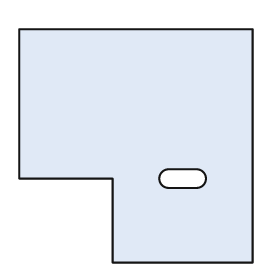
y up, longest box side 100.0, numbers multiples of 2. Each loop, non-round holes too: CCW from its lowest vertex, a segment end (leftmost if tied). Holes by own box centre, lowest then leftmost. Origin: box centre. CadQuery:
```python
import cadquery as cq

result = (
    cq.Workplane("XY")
    .moveTo(-10.0, -50.0)
    .lineTo(50.0, -50.0)
    .lineTo(50.0, 50.0)
    .lineTo(-50.0, 50.0)
    .lineTo(-50.0, -14.0)
    .lineTo(-10.0, -14.0)
    .close()
    .moveTo(14.0, -18.0)
    .lineTo(26.0, -18.0)
    .threePointArc((30.0, -14.0), (26.0, -10.0))
    .lineTo(14.0, -10.0)
    .threePointArc((10.0, -14.0), (14.0, -18.0))
    .close()
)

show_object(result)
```